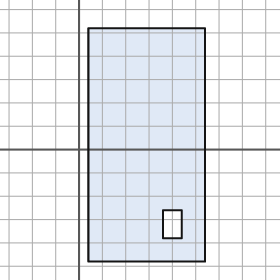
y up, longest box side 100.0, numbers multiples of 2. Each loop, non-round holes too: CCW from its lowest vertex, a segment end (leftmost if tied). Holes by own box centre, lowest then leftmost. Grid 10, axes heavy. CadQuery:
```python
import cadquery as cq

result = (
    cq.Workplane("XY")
    .moveTo(4.0, -48.0)
    .lineTo(54.0, -48.0)
    .lineTo(54.0, 52.0)
    .lineTo(4.0, 52.0)
    .close()
    .moveTo(36.0, -38.0)
    .lineTo(44.0, -38.0)
    .lineTo(44.0, -26.0)
    .lineTo(36.0, -26.0)
    .close()
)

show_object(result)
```